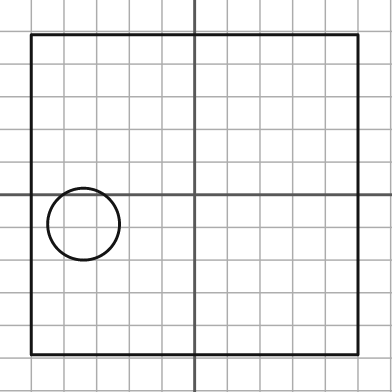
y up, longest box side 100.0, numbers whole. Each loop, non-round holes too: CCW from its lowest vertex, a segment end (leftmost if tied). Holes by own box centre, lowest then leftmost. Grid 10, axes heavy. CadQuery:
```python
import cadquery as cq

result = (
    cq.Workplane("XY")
    .moveTo(-50.0, -49.0)
    .lineTo(50.0, -49.0)
    .lineTo(50.0, 49.0)
    .lineTo(-50.0, 49.0)
    .close()
    .moveTo(-34.0, -9.0)
    .circle(11.0)
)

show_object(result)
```